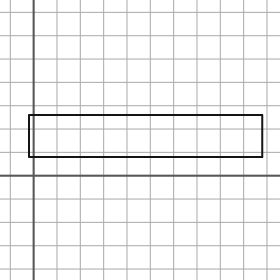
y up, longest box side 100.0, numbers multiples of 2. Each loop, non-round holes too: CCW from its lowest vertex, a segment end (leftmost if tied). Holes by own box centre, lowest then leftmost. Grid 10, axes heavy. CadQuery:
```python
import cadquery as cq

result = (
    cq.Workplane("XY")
    .moveTo(-2.0, 8.0)
    .lineTo(98.0, 8.0)
    .lineTo(98.0, 26.0)
    .lineTo(-2.0, 26.0)
    .close()
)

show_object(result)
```